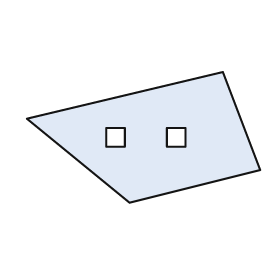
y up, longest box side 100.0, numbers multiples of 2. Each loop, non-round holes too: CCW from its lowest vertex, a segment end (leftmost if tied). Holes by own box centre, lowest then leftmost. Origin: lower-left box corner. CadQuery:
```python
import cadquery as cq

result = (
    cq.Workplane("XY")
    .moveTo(44.0, 0.0)
    .lineTo(100.0, 14.0)
    .lineTo(84.0, 56.0)
    .lineTo(0.0, 36.0)
    .close()
    .moveTo(34.0, 24.0)
    .lineTo(42.0, 24.0)
    .lineTo(42.0, 32.0)
    .lineTo(34.0, 32.0)
    .close()
    .moveTo(60.0, 24.0)
    .lineTo(68.0, 24.0)
    .lineTo(68.0, 32.0)
    .lineTo(60.0, 32.0)
    .close()
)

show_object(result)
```